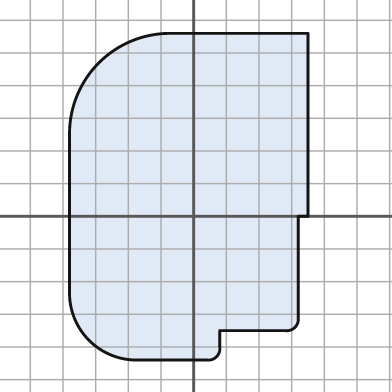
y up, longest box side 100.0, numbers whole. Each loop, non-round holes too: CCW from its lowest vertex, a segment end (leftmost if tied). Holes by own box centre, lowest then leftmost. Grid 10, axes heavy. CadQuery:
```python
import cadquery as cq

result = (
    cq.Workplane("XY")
    .moveTo(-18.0, -44.0)
    .lineTo(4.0, -44.0)
    .threePointArc((7.0, -43.0), (8.0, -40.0))
    .lineTo(8.0, -35.0)
    .lineTo(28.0, -35.0)
    .threePointArc((31.0, -34.0), (32.0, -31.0))
    .lineTo(32.0, 0.0)
    .lineTo(35.0, 0.0)
    .lineTo(35.0, 56.0)
    .lineTo(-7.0, 56.0)
    .threePointArc((-29.0, 47.0), (-38.0, 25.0))
    .lineTo(-38.0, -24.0)
    .threePointArc((-32.0, -38.0), (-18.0, -44.0))
    .close()
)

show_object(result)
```